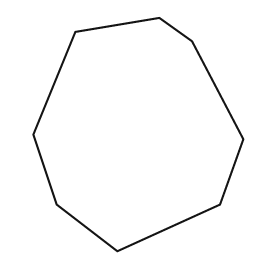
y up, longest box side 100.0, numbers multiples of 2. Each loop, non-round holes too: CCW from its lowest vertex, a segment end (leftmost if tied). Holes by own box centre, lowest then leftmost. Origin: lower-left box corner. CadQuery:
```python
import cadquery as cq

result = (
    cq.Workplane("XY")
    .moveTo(36.0, 0.0)
    .lineTo(80.0, 20.0)
    .lineTo(90.0, 48.0)
    .lineTo(68.0, 90.0)
    .lineTo(54.0, 100.0)
    .lineTo(18.0, 94.0)
    .lineTo(0.0, 50.0)
    .lineTo(10.0, 20.0)
    .close()
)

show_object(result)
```